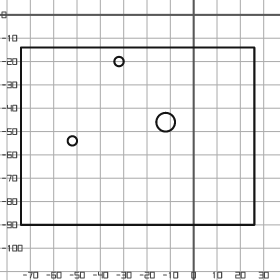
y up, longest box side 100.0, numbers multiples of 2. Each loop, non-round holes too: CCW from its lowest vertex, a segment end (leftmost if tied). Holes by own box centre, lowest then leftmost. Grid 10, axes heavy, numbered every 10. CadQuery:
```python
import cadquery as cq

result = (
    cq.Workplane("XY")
    .moveTo(-74.0, -90.0)
    .lineTo(26.0, -90.0)
    .lineTo(26.0, -14.0)
    .lineTo(-74.0, -14.0)
    .close()
    .moveTo(-52.0, -54.0)
    .circle(2.0)
    .moveTo(-12.0, -46.0)
    .circle(4.0)
    .moveTo(-32.0, -20.0)
    .circle(2.0)
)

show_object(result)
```